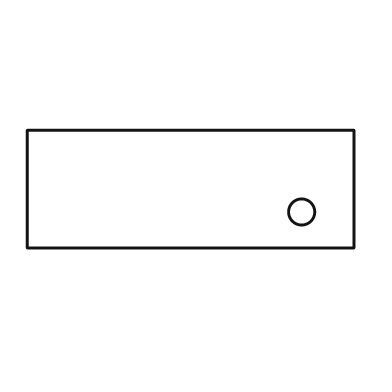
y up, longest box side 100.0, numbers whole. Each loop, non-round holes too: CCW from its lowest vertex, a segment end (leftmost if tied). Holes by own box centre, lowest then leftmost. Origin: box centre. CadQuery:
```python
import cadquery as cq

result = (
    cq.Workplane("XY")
    .moveTo(-50.0, -18.0)
    .lineTo(50.0, -18.0)
    .lineTo(50.0, 18.0)
    .lineTo(-50.0, 18.0)
    .close()
    .moveTo(34.0, -7.0)
    .circle(4.0)
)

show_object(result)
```